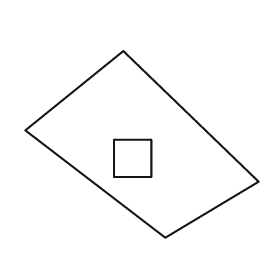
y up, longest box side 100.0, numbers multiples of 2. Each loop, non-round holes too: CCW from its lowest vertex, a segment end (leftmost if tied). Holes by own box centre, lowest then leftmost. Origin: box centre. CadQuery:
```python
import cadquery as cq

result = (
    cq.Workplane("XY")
    .moveTo(10.0, -40.0)
    .lineTo(50.0, -16.0)
    .lineTo(-8.0, 40.0)
    .lineTo(-50.0, 6.0)
    .close()
    .moveTo(-12.0, -14.0)
    .lineTo(4.0, -14.0)
    .lineTo(4.0, 2.0)
    .lineTo(-12.0, 2.0)
    .close()
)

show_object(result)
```